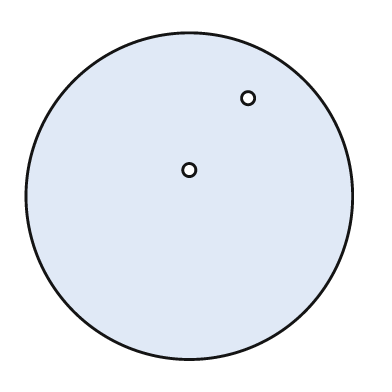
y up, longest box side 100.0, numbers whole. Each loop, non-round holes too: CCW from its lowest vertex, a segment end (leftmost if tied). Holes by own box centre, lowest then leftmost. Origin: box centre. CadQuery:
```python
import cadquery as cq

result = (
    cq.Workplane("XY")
    .moveTo(0.0, 0.0)
    .circle(50.0)
    .moveTo(0.0, 8.0)
    .circle(2.0)
    .moveTo(18.0, 30.0)
    .circle(2.0)
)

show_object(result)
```